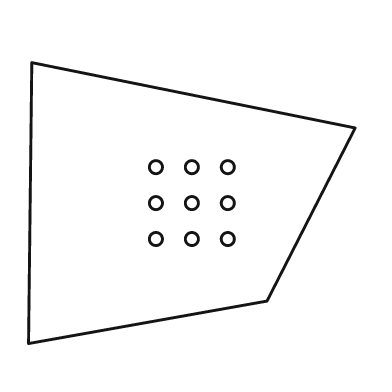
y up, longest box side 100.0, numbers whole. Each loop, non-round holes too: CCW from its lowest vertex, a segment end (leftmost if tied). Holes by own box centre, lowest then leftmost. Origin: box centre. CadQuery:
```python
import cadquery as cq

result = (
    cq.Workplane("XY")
    .moveTo(-50.0, -43.0)
    .lineTo(23.0, -30.0)
    .lineTo(50.0, 23.0)
    .lineTo(-49.0, 43.0)
    .close()
    .moveTo(-11.0, -11.0)
    .circle(2.0)
    .moveTo(0.0, -11.0)
    .circle(2.0)
    .moveTo(11.0, -11.0)
    .circle(2.0)
    .moveTo(-11.0, 0.0)
    .circle(2.0)
    .moveTo(0.0, 0.0)
    .circle(2.0)
    .moveTo(11.0, 0.0)
    .circle(2.0)
    .moveTo(-11.0, 11.0)
    .circle(2.0)
    .moveTo(0.0, 11.0)
    .circle(2.0)
    .moveTo(11.0, 11.0)
    .circle(2.0)
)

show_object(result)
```